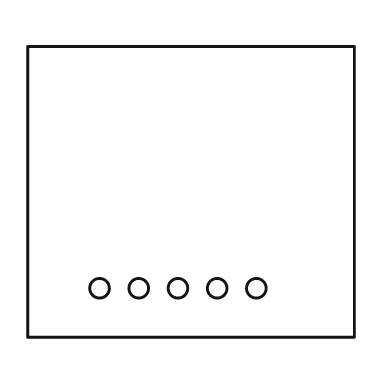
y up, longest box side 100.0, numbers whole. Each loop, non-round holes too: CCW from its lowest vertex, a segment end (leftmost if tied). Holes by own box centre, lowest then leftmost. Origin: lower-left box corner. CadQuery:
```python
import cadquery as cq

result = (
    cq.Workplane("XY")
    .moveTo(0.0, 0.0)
    .lineTo(100.0, 0.0)
    .lineTo(100.0, 89.0)
    .lineTo(0.0, 89.0)
    .close()
    .moveTo(22.0, 15.0)
    .circle(3.0)
    .moveTo(34.0, 15.0)
    .circle(3.0)
    .moveTo(46.0, 15.0)
    .circle(3.0)
    .moveTo(58.0, 15.0)
    .circle(3.0)
    .moveTo(70.0, 15.0)
    .circle(3.0)
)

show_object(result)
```